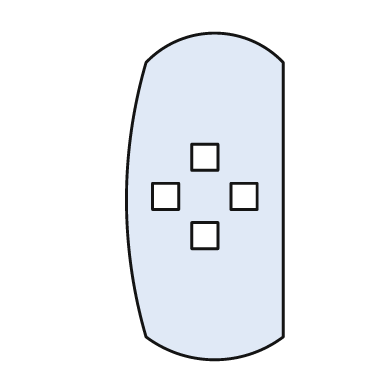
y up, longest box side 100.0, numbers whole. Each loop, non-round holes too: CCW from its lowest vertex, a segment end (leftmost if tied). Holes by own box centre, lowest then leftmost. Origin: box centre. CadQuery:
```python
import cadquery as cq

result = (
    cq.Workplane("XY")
    .moveTo(-18.0, -43.0)
    .threePointArc((3.0, -50.0), (24.0, -43.0))
    .lineTo(24.0, 41.0)
    .threePointArc((3.0, 50.0), (-18.0, 41.0))
    .threePointArc((-24.0, -1.0), (-18.0, -43.0))
    .close()
    .moveTo(-4.0, -16.0)
    .lineTo(4.0, -16.0)
    .lineTo(4.0, -8.0)
    .lineTo(-4.0, -8.0)
    .close()
    .moveTo(-16.0, -4.0)
    .lineTo(-8.0, -4.0)
    .lineTo(-8.0, 4.0)
    .lineTo(-16.0, 4.0)
    .close()
    .moveTo(8.0, -4.0)
    .lineTo(16.0, -4.0)
    .lineTo(16.0, 4.0)
    .lineTo(8.0, 4.0)
    .close()
    .moveTo(-4.0, 8.0)
    .lineTo(4.0, 8.0)
    .lineTo(4.0, 16.0)
    .lineTo(-4.0, 16.0)
    .close()
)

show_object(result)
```